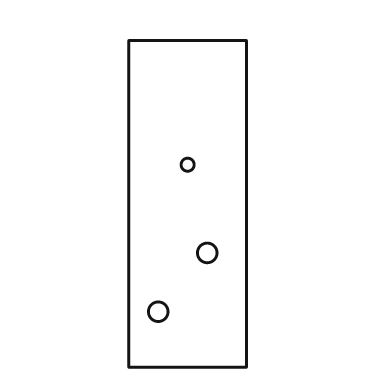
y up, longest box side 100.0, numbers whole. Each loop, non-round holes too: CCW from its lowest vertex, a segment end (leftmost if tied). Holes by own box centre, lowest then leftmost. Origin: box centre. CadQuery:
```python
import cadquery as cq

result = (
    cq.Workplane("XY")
    .moveTo(-18.0, -50.0)
    .lineTo(18.0, -50.0)
    .lineTo(18.0, 50.0)
    .lineTo(-18.0, 50.0)
    .close()
    .moveTo(-9.0, -33.0)
    .circle(3.0)
    .moveTo(6.0, -15.0)
    .circle(3.0)
    .moveTo(0.0, 12.0)
    .circle(2.0)
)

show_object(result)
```